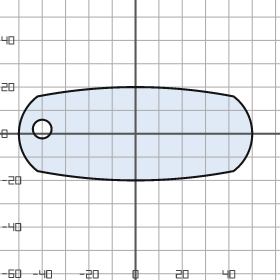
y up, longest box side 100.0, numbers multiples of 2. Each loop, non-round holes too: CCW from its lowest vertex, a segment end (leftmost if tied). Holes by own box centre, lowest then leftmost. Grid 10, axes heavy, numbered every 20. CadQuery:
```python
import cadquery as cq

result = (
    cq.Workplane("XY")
    .moveTo(-42.0, -16.0)
    .threePointArc((0.0, -20.0), (42.0, -16.0))
    .threePointArc((50.0, 0.0), (42.0, 16.0))
    .threePointArc((0.0, 20.0), (-42.0, 16.0))
    .threePointArc((-50.0, 0.0), (-42.0, -16.0))
    .close()
    .moveTo(-40.0, 2.0)
    .circle(4.0)
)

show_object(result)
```